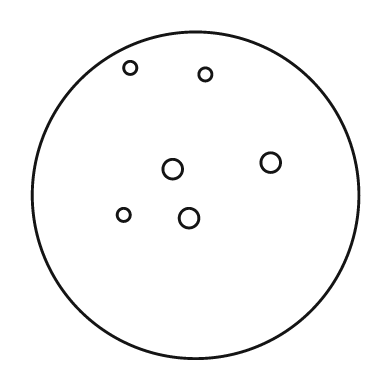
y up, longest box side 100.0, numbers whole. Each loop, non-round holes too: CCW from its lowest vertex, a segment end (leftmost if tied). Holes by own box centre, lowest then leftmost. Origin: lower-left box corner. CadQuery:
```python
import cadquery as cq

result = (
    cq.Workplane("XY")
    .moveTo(50.0, 50.0)
    .circle(50.0)
    .moveTo(48.0, 43.0)
    .circle(3.0)
    .moveTo(28.0, 44.0)
    .circle(2.0)
    .moveTo(43.0, 58.0)
    .circle(3.0)
    .moveTo(73.0, 60.0)
    .circle(3.0)
    .moveTo(53.0, 87.0)
    .circle(2.0)
    .moveTo(30.0, 89.0)
    .circle(2.0)
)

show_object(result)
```